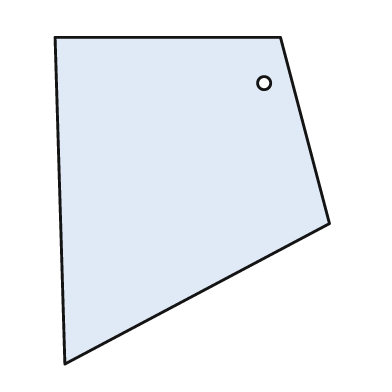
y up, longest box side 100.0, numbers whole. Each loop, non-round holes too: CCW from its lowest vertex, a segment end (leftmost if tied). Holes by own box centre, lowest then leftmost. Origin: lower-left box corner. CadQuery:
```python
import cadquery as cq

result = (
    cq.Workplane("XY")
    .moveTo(3.0, 0.0)
    .lineTo(84.0, 43.0)
    .lineTo(69.0, 100.0)
    .lineTo(0.0, 100.0)
    .close()
    .moveTo(64.0, 86.0)
    .circle(2.0)
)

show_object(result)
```